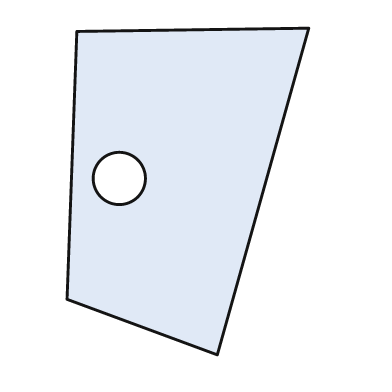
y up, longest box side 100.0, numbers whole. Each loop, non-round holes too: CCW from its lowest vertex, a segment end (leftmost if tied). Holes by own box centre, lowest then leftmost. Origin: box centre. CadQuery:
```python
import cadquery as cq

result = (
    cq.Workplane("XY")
    .moveTo(9.0, -50.0)
    .lineTo(37.0, 50.0)
    .lineTo(-34.0, 49.0)
    .lineTo(-37.0, -33.0)
    .close()
    .moveTo(-21.0, 4.0)
    .circle(8.0)
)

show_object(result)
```